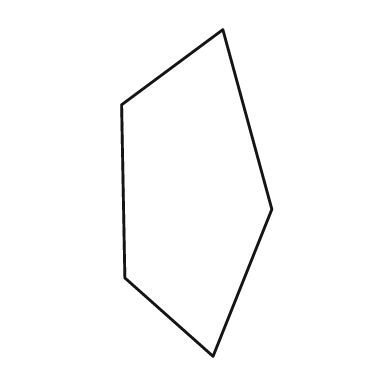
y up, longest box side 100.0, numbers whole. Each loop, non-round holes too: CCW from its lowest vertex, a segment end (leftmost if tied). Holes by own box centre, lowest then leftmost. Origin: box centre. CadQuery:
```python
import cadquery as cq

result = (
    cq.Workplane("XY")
    .moveTo(5.0, -50.0)
    .lineTo(23.0, -5.0)
    .lineTo(8.0, 50.0)
    .lineTo(-23.0, 27.0)
    .lineTo(-22.0, -26.0)
    .close()
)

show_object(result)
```